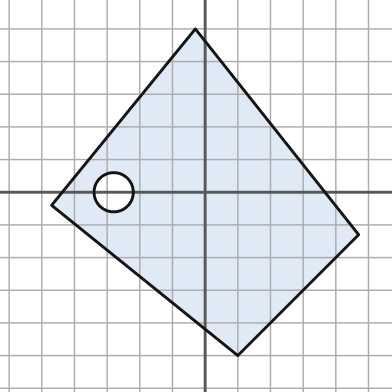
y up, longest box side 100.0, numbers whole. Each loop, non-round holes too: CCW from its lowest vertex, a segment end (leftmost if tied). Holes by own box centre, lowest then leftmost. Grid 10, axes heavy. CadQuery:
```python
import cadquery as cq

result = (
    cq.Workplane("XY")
    .moveTo(10.0, -50.0)
    .lineTo(47.0, -13.0)
    .lineTo(-3.0, 50.0)
    .lineTo(-47.0, -4.0)
    .close()
    .moveTo(-28.0, 0.0)
    .circle(6.0)
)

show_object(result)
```